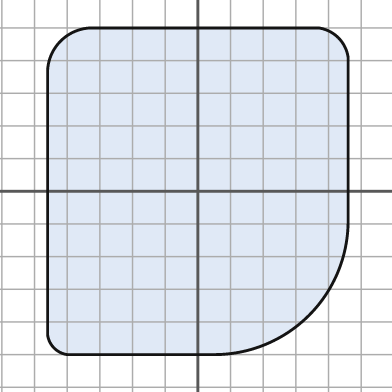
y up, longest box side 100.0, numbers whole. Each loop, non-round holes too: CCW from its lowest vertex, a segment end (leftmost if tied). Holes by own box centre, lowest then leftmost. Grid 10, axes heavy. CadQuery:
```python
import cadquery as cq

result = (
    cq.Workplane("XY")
    .moveTo(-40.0, -50.0)
    .lineTo(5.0, -50.0)
    .threePointArc((34.0, -38.0), (46.0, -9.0))
    .lineTo(46.0, 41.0)
    .threePointArc((43.0, 47.0), (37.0, 50.0))
    .lineTo(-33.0, 50.0)
    .threePointArc((-42.0, 46.0), (-46.0, 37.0))
    .lineTo(-46.0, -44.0)
    .threePointArc((-44.0, -48.0), (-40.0, -50.0))
    .close()
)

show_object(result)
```